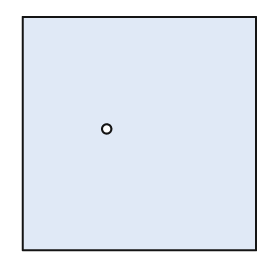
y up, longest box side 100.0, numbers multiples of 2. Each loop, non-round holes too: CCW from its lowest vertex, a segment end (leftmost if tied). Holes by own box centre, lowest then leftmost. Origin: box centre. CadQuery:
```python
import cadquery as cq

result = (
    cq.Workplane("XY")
    .moveTo(-50.0, -50.0)
    .lineTo(50.0, -50.0)
    .lineTo(50.0, 50.0)
    .lineTo(-50.0, 50.0)
    .close()
    .moveTo(-14.0, 2.0)
    .circle(2.0)
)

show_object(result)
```